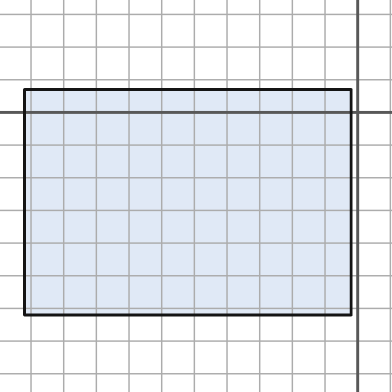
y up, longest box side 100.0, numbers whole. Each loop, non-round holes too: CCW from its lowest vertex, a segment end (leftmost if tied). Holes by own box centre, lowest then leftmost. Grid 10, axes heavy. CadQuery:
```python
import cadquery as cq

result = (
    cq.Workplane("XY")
    .moveTo(-102.0, -62.0)
    .lineTo(-2.0, -62.0)
    .lineTo(-2.0, 7.0)
    .lineTo(-102.0, 7.0)
    .close()
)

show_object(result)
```